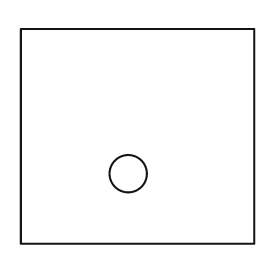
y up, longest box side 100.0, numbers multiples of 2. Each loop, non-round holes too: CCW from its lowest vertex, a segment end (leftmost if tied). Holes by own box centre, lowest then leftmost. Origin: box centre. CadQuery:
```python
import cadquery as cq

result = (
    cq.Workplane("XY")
    .moveTo(-50.0, -46.0)
    .lineTo(50.0, -46.0)
    .lineTo(50.0, 46.0)
    .lineTo(-50.0, 46.0)
    .close()
    .moveTo(-4.0, -16.0)
    .circle(8.0)
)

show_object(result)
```